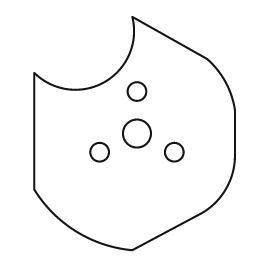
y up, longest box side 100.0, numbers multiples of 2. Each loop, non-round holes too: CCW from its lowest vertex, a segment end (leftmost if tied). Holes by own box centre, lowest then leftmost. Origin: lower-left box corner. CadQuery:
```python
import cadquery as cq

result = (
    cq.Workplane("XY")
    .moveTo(42.0, 0.0)
    .lineTo(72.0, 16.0)
    .threePointArc((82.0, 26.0), (86.0, 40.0))
    .lineTo(86.0, 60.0)
    .threePointArc((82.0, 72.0), (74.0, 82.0))
    .lineTo(42.0, 100.0)
    .threePointArc((30.0, 72.0), (0.0, 76.0))
    .lineTo(0.0, 26.0)
    .threePointArc((18.0, 8.0), (42.0, 0.0))
    .close()
    .moveTo(28.0, 42.0)
    .circle(4.0)
    .moveTo(60.0, 42.0)
    .circle(4.0)
    .moveTo(44.0, 50.0)
    .circle(6.0)
    .moveTo(44.0, 68.0)
    .circle(4.0)
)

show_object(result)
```